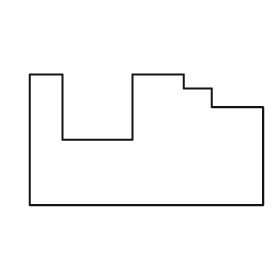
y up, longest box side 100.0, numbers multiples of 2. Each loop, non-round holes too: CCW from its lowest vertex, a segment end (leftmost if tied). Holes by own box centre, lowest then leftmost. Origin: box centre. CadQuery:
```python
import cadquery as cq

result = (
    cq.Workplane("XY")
    .moveTo(-50.0, -28.0)
    .lineTo(50.0, -28.0)
    .lineTo(50.0, 14.0)
    .lineTo(28.0, 14.0)
    .lineTo(28.0, 22.0)
    .lineTo(16.0, 22.0)
    .lineTo(16.0, 28.0)
    .lineTo(-6.0, 28.0)
    .lineTo(-6.0, 0.0)
    .lineTo(-36.0, 0.0)
    .lineTo(-36.0, 28.0)
    .lineTo(-50.0, 28.0)
    .close()
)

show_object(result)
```